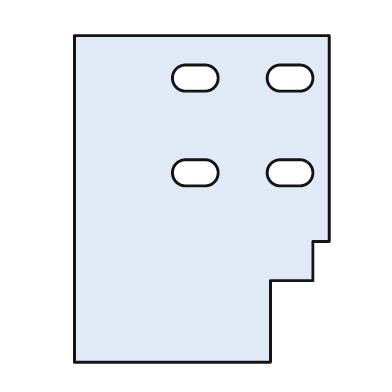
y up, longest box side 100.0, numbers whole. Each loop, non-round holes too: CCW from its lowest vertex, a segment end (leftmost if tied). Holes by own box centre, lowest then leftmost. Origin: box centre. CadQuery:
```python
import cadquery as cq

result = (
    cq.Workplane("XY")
    .moveTo(-39.0, -50.0)
    .lineTo(21.0, -50.0)
    .lineTo(21.0, -25.0)
    .lineTo(34.0, -25.0)
    .lineTo(34.0, -13.0)
    .lineTo(39.0, -13.0)
    .lineTo(39.0, 50.0)
    .lineTo(-39.0, 50.0)
    .close()
    .moveTo(-5.0, 4.0)
    .lineTo(1.0, 4.0)
    .threePointArc((5.0, 8.0), (1.0, 12.0))
    .lineTo(-5.0, 12.0)
    .threePointArc((-9.0, 8.0), (-5.0, 4.0))
    .close()
    .moveTo(24.0, 4.0)
    .lineTo(30.0, 4.0)
    .threePointArc((34.0, 8.0), (30.0, 12.0))
    .lineTo(24.0, 12.0)
    .threePointArc((20.0, 8.0), (24.0, 4.0))
    .close()
    .moveTo(-5.0, 33.0)
    .lineTo(1.0, 33.0)
    .threePointArc((5.0, 37.0), (1.0, 41.0))
    .lineTo(-5.0, 41.0)
    .threePointArc((-9.0, 37.0), (-5.0, 33.0))
    .close()
    .moveTo(24.0, 33.0)
    .lineTo(30.0, 33.0)
    .threePointArc((34.0, 37.0), (30.0, 41.0))
    .lineTo(24.0, 41.0)
    .threePointArc((20.0, 37.0), (24.0, 33.0))
    .close()
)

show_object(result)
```